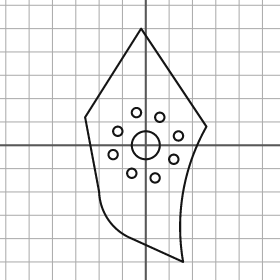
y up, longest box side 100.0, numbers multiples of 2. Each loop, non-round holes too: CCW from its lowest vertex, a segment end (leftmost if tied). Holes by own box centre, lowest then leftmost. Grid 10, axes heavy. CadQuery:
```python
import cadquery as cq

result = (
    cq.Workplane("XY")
    .moveTo(16.0, -50.0)
    .threePointArc((16.0, -20.0), (26.0, 8.0))
    .lineTo(-2.0, 50.0)
    .lineTo(-26.0, 12.0)
    .lineTo(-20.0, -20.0)
    .threePointArc((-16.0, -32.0), (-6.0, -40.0))
    .close()
    .moveTo(4.0, -14.0)
    .circle(2.0)
    .moveTo(-6.0, -12.0)
    .circle(2.0)
    .moveTo(12.0, -6.0)
    .circle(2.0)
    .moveTo(-14.0, -4.0)
    .circle(2.0)
    .moveTo(0.0, 0.0)
    .circle(6.0)
    .moveTo(14.0, 4.0)
    .circle(2.0)
    .moveTo(-12.0, 6.0)
    .circle(2.0)
    .moveTo(6.0, 12.0)
    .circle(2.0)
    .moveTo(-4.0, 14.0)
    .circle(2.0)
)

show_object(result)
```